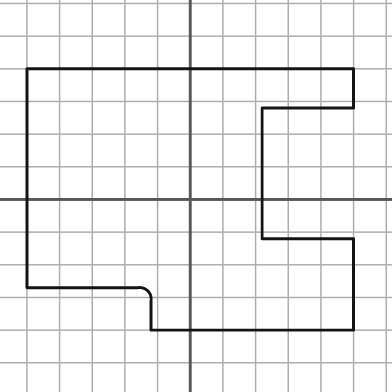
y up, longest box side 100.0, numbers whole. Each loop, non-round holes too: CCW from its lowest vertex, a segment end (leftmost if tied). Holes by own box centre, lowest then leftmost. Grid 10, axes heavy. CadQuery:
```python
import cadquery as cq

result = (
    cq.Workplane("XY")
    .moveTo(-12.0, -40.0)
    .lineTo(50.0, -40.0)
    .lineTo(50.0, -12.0)
    .lineTo(22.0, -12.0)
    .lineTo(22.0, 28.0)
    .lineTo(50.0, 28.0)
    .lineTo(50.0, 40.0)
    .lineTo(-50.0, 40.0)
    .lineTo(-50.0, -27.0)
    .lineTo(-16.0, -27.0)
    .threePointArc((-13.0, -28.0), (-12.0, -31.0))
    .close()
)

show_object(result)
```